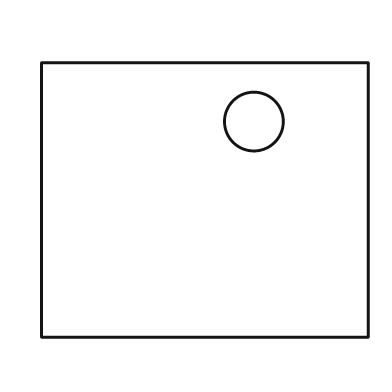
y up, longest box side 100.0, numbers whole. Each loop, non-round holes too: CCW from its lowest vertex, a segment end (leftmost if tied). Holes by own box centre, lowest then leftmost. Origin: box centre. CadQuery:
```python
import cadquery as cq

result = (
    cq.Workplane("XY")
    .moveTo(-50.0, -42.0)
    .lineTo(50.0, -42.0)
    .lineTo(50.0, 42.0)
    .lineTo(-50.0, 42.0)
    .close()
    .moveTo(15.0, 24.0)
    .circle(9.0)
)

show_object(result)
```